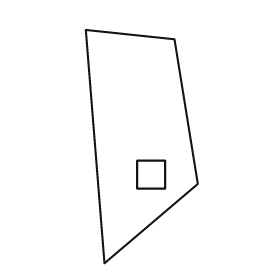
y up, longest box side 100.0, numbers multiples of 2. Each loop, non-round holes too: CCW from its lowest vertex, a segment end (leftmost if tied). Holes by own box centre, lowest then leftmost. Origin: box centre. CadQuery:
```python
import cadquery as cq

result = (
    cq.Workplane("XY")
    .moveTo(-16.0, -50.0)
    .lineTo(24.0, -16.0)
    .lineTo(14.0, 46.0)
    .lineTo(-24.0, 50.0)
    .close()
    .moveTo(-2.0, -18.0)
    .lineTo(10.0, -18.0)
    .lineTo(10.0, -6.0)
    .lineTo(-2.0, -6.0)
    .close()
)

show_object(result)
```